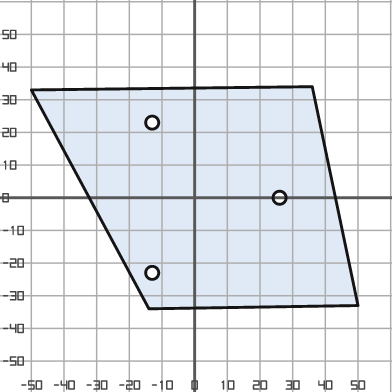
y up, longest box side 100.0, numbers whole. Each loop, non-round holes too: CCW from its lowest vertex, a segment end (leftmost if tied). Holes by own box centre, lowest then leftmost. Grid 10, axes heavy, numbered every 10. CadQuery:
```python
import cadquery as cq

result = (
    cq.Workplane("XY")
    .moveTo(-14.0, -34.0)
    .lineTo(50.0, -33.0)
    .lineTo(36.0, 34.0)
    .lineTo(-50.0, 33.0)
    .close()
    .moveTo(-13.0, -23.0)
    .circle(2.0)
    .moveTo(26.0, 0.0)
    .circle(2.0)
    .moveTo(-13.0, 23.0)
    .circle(2.0)
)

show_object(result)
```